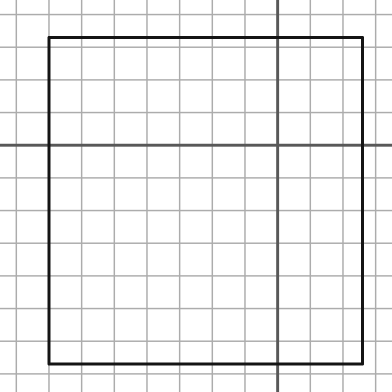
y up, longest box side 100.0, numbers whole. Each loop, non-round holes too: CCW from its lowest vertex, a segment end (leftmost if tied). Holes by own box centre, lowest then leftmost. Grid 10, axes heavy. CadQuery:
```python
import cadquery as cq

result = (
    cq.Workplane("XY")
    .moveTo(-70.0, -67.0)
    .lineTo(26.0, -67.0)
    .lineTo(26.0, 33.0)
    .lineTo(-70.0, 33.0)
    .close()
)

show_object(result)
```